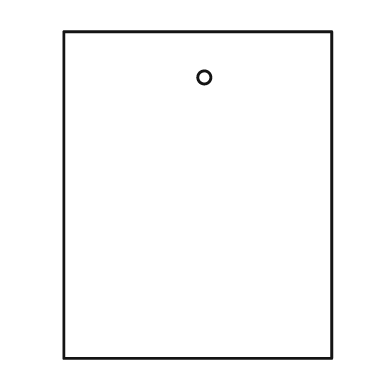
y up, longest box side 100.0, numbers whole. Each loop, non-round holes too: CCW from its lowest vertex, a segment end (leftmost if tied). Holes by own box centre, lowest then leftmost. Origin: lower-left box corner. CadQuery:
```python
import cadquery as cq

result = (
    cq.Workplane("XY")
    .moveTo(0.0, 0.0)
    .lineTo(82.0, 0.0)
    .lineTo(82.0, 100.0)
    .lineTo(0.0, 100.0)
    .close()
    .moveTo(43.0, 86.0)
    .circle(2.0)
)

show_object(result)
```